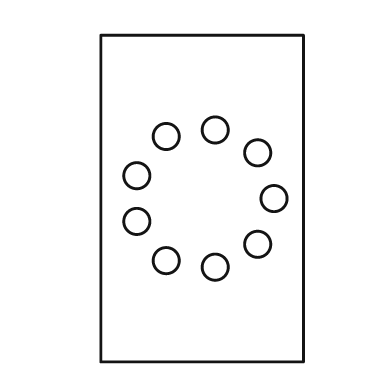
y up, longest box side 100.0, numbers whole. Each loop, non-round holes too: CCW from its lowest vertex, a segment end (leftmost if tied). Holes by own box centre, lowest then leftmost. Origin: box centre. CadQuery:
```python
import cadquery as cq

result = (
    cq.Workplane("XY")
    .moveTo(-31.0, -50.0)
    .lineTo(31.0, -50.0)
    .lineTo(31.0, 50.0)
    .lineTo(-31.0, 50.0)
    .close()
    .moveTo(4.0, -21.0)
    .circle(4.0)
    .moveTo(-11.0, -19.0)
    .circle(4.0)
    .moveTo(17.0, -14.0)
    .circle(4.0)
    .moveTo(-20.0, -7.0)
    .circle(4.0)
    .moveTo(22.0, 0.0)
    .circle(4.0)
    .moveTo(-20.0, 7.0)
    .circle(4.0)
    .moveTo(17.0, 14.0)
    .circle(4.0)
    .moveTo(-11.0, 19.0)
    .circle(4.0)
    .moveTo(4.0, 21.0)
    .circle(4.0)
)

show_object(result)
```